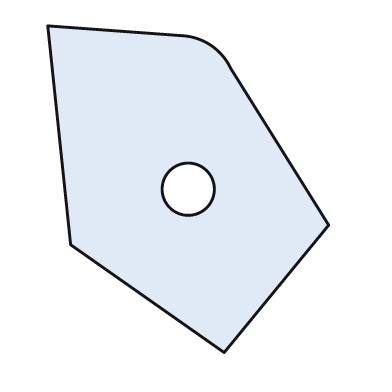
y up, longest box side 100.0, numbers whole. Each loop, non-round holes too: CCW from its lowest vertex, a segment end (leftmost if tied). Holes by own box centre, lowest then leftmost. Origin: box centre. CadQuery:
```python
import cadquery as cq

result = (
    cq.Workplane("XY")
    .moveTo(11.0, -50.0)
    .lineTo(43.0, -11.0)
    .lineTo(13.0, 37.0)
    .threePointArc((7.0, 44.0), (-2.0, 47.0))
    .lineTo(-43.0, 50.0)
    .lineTo(-36.0, -17.0)
    .close()
    .moveTo(0.0, 0.0)
    .circle(8.0)
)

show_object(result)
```